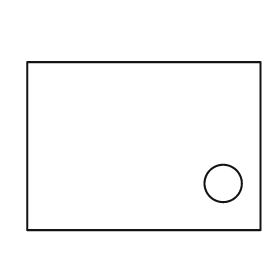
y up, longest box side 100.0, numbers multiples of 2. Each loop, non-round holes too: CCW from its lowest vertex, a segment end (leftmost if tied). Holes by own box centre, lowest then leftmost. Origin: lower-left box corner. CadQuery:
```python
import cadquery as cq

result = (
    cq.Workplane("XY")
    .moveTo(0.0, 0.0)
    .lineTo(100.0, 0.0)
    .lineTo(100.0, 72.0)
    .lineTo(0.0, 72.0)
    .close()
    .moveTo(84.0, 20.0)
    .circle(8.0)
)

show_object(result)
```